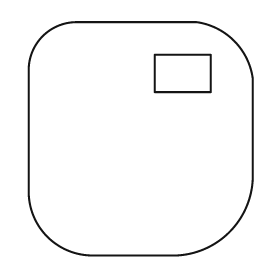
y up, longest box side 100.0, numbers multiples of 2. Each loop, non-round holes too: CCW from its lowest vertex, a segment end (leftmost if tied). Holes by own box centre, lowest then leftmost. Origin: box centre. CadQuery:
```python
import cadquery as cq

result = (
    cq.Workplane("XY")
    .moveTo(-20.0, -50.0)
    .lineTo(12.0, -50.0)
    .threePointArc((38.0, -40.0), (48.0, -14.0))
    .lineTo(48.0, 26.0)
    .threePointArc((40.0, 42.0), (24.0, 50.0))
    .lineTo(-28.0, 50.0)
    .threePointArc((-42.0, 44.0), (-48.0, 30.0))
    .lineTo(-48.0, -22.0)
    .threePointArc((-40.0, -42.0), (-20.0, -50.0))
    .close()
    .moveTo(6.0, 20.0)
    .lineTo(30.0, 20.0)
    .lineTo(30.0, 36.0)
    .lineTo(6.0, 36.0)
    .close()
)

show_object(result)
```